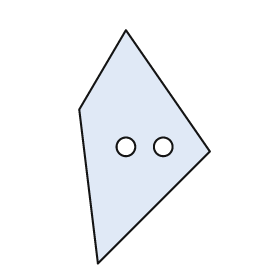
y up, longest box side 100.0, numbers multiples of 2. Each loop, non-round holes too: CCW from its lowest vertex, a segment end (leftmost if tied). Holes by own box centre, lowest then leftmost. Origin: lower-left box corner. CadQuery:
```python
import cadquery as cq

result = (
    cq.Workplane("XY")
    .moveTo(8.0, 0.0)
    .lineTo(56.0, 48.0)
    .lineTo(20.0, 100.0)
    .lineTo(0.0, 66.0)
    .close()
    .moveTo(20.0, 50.0)
    .circle(4.0)
    .moveTo(36.0, 50.0)
    .circle(4.0)
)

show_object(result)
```